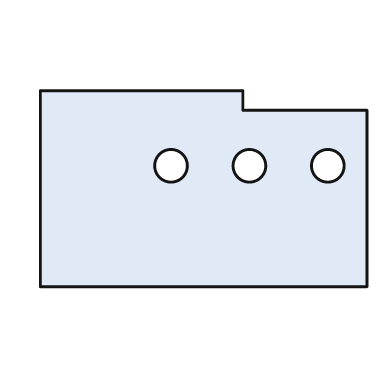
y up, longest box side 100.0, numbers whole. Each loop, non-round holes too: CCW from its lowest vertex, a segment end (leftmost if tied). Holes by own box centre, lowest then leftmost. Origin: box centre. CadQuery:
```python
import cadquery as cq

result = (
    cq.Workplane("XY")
    .moveTo(-50.0, -30.0)
    .lineTo(50.0, -30.0)
    .lineTo(50.0, 24.0)
    .lineTo(12.0, 24.0)
    .lineTo(12.0, 30.0)
    .lineTo(-50.0, 30.0)
    .close()
    .moveTo(-10.0, 7.0)
    .circle(5.0)
    .moveTo(14.0, 7.0)
    .circle(5.0)
    .moveTo(38.0, 7.0)
    .circle(5.0)
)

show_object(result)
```